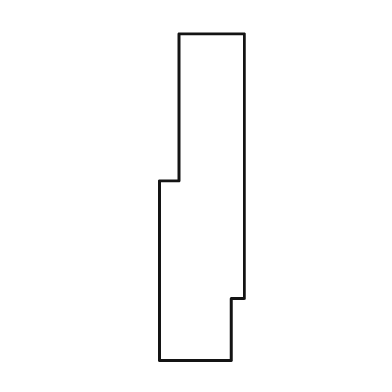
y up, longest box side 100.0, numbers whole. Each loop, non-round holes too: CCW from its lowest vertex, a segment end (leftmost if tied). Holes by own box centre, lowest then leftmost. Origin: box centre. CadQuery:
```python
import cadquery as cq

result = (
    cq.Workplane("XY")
    .moveTo(-13.0, -50.0)
    .lineTo(9.0, -50.0)
    .lineTo(9.0, -31.0)
    .lineTo(13.0, -31.0)
    .lineTo(13.0, 50.0)
    .lineTo(-7.0, 50.0)
    .lineTo(-7.0, 5.0)
    .lineTo(-13.0, 5.0)
    .close()
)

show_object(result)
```